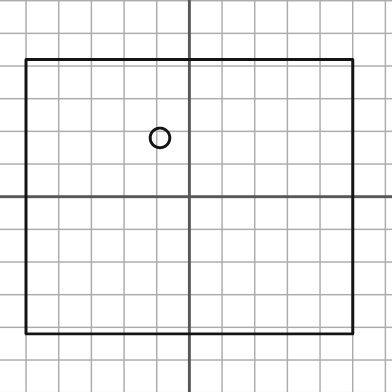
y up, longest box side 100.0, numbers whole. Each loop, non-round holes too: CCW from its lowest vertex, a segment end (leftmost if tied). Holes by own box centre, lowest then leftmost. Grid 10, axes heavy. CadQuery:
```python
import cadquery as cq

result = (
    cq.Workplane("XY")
    .moveTo(-50.0, -42.0)
    .lineTo(50.0, -42.0)
    .lineTo(50.0, 42.0)
    .lineTo(-50.0, 42.0)
    .close()
    .moveTo(-9.0, 18.0)
    .circle(3.0)
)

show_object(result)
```